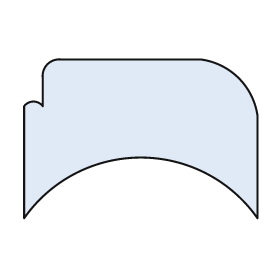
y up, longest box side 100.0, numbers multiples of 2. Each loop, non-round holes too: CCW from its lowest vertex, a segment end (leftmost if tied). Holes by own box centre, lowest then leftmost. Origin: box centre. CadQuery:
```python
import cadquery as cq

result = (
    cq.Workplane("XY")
    .moveTo(-50.0, -34.0)
    .threePointArc((0.0, -8.0), (50.0, -34.0))
    .lineTo(50.0, 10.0)
    .threePointArc((42.0, 26.0), (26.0, 34.0))
    .lineTo(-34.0, 34.0)
    .threePointArc((-40.0, 32.0), (-42.0, 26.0))
    .lineTo(-42.0, 14.0)
    .threePointArc((-46.0, 16.0), (-50.0, 14.0))
    .close()
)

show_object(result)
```